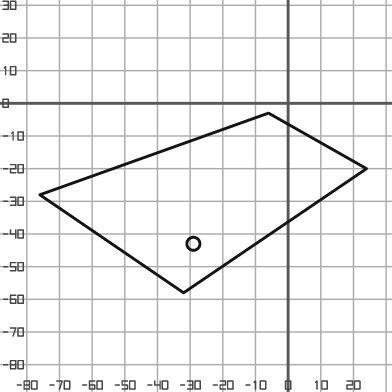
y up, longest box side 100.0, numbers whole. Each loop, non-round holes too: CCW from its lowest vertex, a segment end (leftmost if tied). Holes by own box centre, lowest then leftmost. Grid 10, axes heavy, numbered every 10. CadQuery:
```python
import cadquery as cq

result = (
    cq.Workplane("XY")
    .moveTo(-32.0, -58.0)
    .lineTo(24.0, -20.0)
    .lineTo(-6.0, -3.0)
    .lineTo(-76.0, -28.0)
    .close()
    .moveTo(-29.0, -43.0)
    .circle(2.0)
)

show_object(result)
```